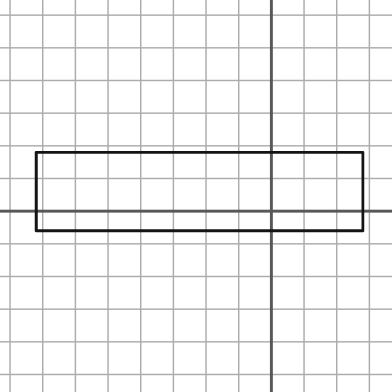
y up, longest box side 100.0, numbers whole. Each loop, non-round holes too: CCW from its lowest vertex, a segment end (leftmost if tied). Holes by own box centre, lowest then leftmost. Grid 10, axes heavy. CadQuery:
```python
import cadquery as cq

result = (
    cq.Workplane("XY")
    .moveTo(-72.0, -6.0)
    .lineTo(28.0, -6.0)
    .lineTo(28.0, 18.0)
    .lineTo(-72.0, 18.0)
    .close()
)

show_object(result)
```